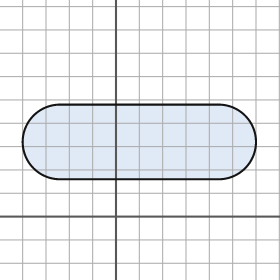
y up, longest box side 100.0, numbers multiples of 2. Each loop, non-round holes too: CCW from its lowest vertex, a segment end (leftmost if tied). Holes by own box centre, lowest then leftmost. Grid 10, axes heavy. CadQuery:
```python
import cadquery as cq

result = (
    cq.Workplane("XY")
    .moveTo(-24.0, 16.0)
    .lineTo(44.0, 16.0)
    .threePointArc((60.0, 32.0), (44.0, 48.0))
    .lineTo(-24.0, 48.0)
    .threePointArc((-40.0, 32.0), (-24.0, 16.0))
    .close()
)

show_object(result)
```